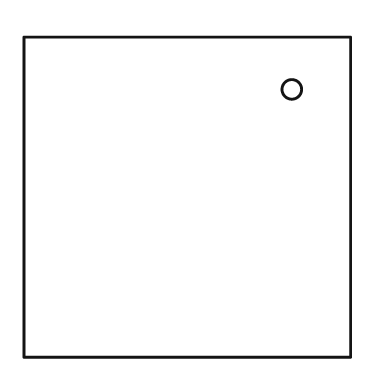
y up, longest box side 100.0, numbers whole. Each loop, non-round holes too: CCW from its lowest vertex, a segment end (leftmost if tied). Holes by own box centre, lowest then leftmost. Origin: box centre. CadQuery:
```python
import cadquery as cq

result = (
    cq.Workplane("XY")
    .moveTo(-50.0, -49.0)
    .lineTo(50.0, -49.0)
    .lineTo(50.0, 49.0)
    .lineTo(-50.0, 49.0)
    .close()
    .moveTo(32.0, 33.0)
    .circle(3.0)
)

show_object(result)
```